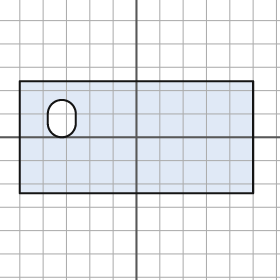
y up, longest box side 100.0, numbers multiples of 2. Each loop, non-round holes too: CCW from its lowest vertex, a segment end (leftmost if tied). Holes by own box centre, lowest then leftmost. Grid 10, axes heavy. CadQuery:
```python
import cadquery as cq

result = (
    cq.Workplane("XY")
    .moveTo(-50.0, -24.0)
    .lineTo(50.0, -24.0)
    .lineTo(50.0, 24.0)
    .lineTo(-50.0, 24.0)
    .close()
    .moveTo(-38.0, 6.0)
    .threePointArc((-32.0, 0.0), (-26.0, 6.0))
    .lineTo(-26.0, 10.0)
    .threePointArc((-32.0, 16.0), (-38.0, 10.0))
    .close()
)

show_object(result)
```